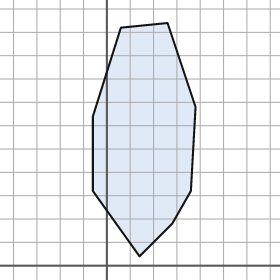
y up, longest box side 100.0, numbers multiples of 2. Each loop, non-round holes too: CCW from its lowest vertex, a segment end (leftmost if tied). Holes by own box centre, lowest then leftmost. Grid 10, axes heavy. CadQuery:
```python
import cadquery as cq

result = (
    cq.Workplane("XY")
    .moveTo(14.0, 4.0)
    .lineTo(28.0, 18.0)
    .lineTo(36.0, 32.0)
    .lineTo(38.0, 68.0)
    .lineTo(26.0, 104.0)
    .lineTo(6.0, 102.0)
    .lineTo(-6.0, 64.0)
    .lineTo(-6.0, 32.0)
    .close()
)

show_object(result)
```